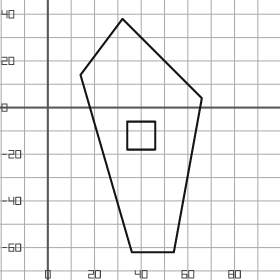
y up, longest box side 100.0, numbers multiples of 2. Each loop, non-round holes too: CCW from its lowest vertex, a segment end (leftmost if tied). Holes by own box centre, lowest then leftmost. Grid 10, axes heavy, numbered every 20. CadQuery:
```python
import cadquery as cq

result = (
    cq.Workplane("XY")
    .moveTo(36.0, -62.0)
    .lineTo(54.0, -62.0)
    .lineTo(66.0, 4.0)
    .lineTo(32.0, 38.0)
    .lineTo(14.0, 14.0)
    .close()
    .moveTo(34.0, -18.0)
    .lineTo(46.0, -18.0)
    .lineTo(46.0, -6.0)
    .lineTo(34.0, -6.0)
    .close()
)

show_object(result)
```